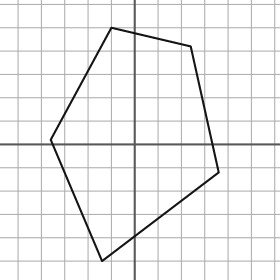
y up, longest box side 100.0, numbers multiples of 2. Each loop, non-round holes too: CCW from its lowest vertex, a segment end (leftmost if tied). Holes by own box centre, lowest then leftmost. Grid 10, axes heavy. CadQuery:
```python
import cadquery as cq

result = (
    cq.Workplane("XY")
    .moveTo(-14.0, -50.0)
    .lineTo(36.0, -12.0)
    .lineTo(24.0, 42.0)
    .lineTo(-10.0, 50.0)
    .lineTo(-36.0, 2.0)
    .close()
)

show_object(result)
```